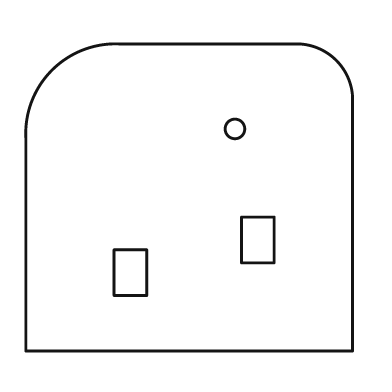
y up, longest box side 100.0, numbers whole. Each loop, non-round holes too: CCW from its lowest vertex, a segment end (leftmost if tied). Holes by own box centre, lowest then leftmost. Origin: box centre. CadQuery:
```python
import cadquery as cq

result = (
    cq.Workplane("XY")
    .moveTo(-50.0, -47.0)
    .lineTo(50.0, -47.0)
    .lineTo(50.0, 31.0)
    .threePointArc((45.0, 42.0), (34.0, 47.0))
    .lineTo(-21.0, 47.0)
    .threePointArc((-42.0, 39.0), (-50.0, 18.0))
    .close()
    .moveTo(-23.0, -30.0)
    .lineTo(-13.0, -30.0)
    .lineTo(-13.0, -16.0)
    .lineTo(-23.0, -16.0)
    .close()
    .moveTo(16.0, -20.0)
    .lineTo(26.0, -20.0)
    .lineTo(26.0, -6.0)
    .lineTo(16.0, -6.0)
    .close()
    .moveTo(14.0, 21.0)
    .circle(3.0)
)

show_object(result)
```